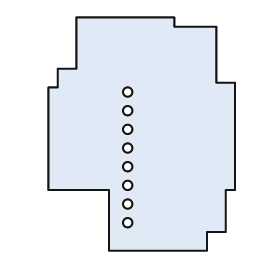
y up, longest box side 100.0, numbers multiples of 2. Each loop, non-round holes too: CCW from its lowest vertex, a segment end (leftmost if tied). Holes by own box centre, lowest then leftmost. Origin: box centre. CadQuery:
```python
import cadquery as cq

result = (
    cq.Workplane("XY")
    .moveTo(-14.0, -50.0)
    .lineTo(28.0, -50.0)
    .lineTo(28.0, -42.0)
    .lineTo(36.0, -42.0)
    .lineTo(36.0, -24.0)
    .lineTo(40.0, -24.0)
    .lineTo(40.0, 22.0)
    .lineTo(32.0, 22.0)
    .lineTo(32.0, 46.0)
    .lineTo(14.0, 46.0)
    .lineTo(14.0, 50.0)
    .lineTo(-28.0, 50.0)
    .lineTo(-28.0, 28.0)
    .lineTo(-36.0, 28.0)
    .lineTo(-36.0, 20.0)
    .lineTo(-40.0, 20.0)
    .lineTo(-40.0, -24.0)
    .lineTo(-14.0, -24.0)
    .close()
    .moveTo(-6.0, -38.0)
    .circle(2.0)
    .moveTo(-6.0, -30.0)
    .circle(2.0)
    .moveTo(-6.0, -22.0)
    .circle(2.0)
    .moveTo(-6.0, -14.0)
    .circle(2.0)
    .moveTo(-6.0, -6.0)
    .circle(2.0)
    .moveTo(-6.0, 2.0)
    .circle(2.0)
    .moveTo(-6.0, 10.0)
    .circle(2.0)
    .moveTo(-6.0, 18.0)
    .circle(2.0)
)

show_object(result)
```